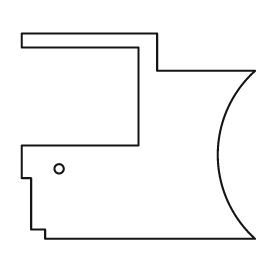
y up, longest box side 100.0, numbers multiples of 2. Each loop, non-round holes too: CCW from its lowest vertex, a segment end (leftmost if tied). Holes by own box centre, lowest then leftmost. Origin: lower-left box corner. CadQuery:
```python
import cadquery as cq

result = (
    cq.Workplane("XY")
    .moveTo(10.0, 0.0)
    .lineTo(100.0, 0.0)
    .threePointArc((84.0, 36.0), (100.0, 72.0))
    .lineTo(58.0, 72.0)
    .lineTo(58.0, 88.0)
    .lineTo(0.0, 88.0)
    .lineTo(0.0, 82.0)
    .lineTo(50.0, 82.0)
    .lineTo(50.0, 40.0)
    .lineTo(0.0, 40.0)
    .lineTo(0.0, 26.0)
    .lineTo(4.0, 26.0)
    .lineTo(4.0, 4.0)
    .lineTo(10.0, 4.0)
    .close()
    .moveTo(16.0, 30.0)
    .circle(2.0)
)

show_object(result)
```